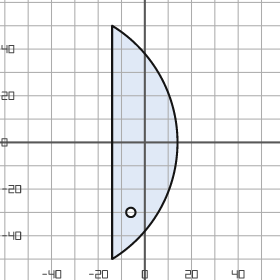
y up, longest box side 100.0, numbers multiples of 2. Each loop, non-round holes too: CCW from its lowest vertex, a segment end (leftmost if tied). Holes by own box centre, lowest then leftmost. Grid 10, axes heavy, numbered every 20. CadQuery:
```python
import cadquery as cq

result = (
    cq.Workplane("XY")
    .moveTo(-14.0, -50.0)
    .threePointArc((14.0, 0.0), (-14.0, 50.0))
    .close()
    .moveTo(-6.0, -30.0)
    .circle(2.0)
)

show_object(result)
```